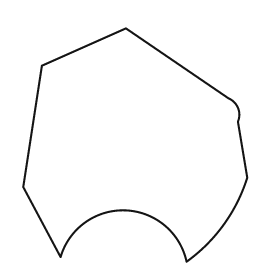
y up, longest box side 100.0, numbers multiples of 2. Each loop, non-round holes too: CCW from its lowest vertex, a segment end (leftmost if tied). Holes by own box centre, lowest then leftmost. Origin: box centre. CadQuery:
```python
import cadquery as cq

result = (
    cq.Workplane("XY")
    .moveTo(22.0, -50.0)
    .threePointArc((38.0, -34.0), (48.0, -14.0))
    .lineTo(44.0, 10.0)
    .threePointArc((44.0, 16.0), (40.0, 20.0))
    .lineTo(-4.0, 50.0)
    .lineTo(-40.0, 34.0)
    .lineTo(-48.0, -18.0)
    .lineTo(-32.0, -48.0)
    .threePointArc((-4.0, -28.0), (22.0, -50.0))
    .close()
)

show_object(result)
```